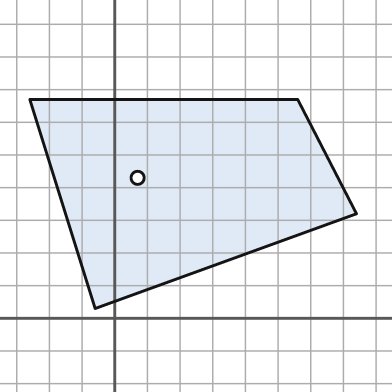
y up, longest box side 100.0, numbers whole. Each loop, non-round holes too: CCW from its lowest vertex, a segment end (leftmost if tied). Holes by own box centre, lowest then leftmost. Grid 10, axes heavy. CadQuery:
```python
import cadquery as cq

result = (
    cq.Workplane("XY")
    .moveTo(-6.0, 3.0)
    .lineTo(74.0, 32.0)
    .lineTo(56.0, 67.0)
    .lineTo(-26.0, 67.0)
    .close()
    .moveTo(7.0, 43.0)
    .circle(2.0)
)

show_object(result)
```